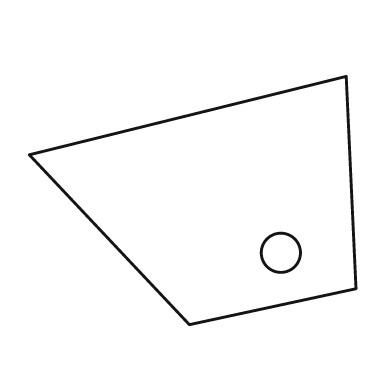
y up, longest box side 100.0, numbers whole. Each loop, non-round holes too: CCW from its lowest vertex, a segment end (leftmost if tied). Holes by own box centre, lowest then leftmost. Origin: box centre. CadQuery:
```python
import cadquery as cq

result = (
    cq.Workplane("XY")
    .moveTo(-1.0, -38.0)
    .lineTo(50.0, -27.0)
    .lineTo(47.0, 38.0)
    .lineTo(-50.0, 14.0)
    .close()
    .moveTo(27.0, -16.0)
    .circle(6.0)
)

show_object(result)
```